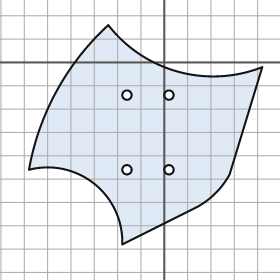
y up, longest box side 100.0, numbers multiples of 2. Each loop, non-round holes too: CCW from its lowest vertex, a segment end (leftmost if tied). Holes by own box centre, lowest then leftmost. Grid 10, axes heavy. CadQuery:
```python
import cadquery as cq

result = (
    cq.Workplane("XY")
    .moveTo(-18.0, -78.0)
    .lineTo(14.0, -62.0)
    .threePointArc((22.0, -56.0), (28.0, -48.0))
    .lineTo(42.0, -2.0)
    .threePointArc((6.0, -4.0), (-24.0, 16.0))
    .threePointArc((-46.0, -12.0), (-58.0, -46.0))
    .threePointArc((-30.0, -52.0), (-18.0, -78.0))
    .close()
    .moveTo(-16.0, -46.0)
    .circle(2.0)
    .moveTo(2.0, -46.0)
    .circle(2.0)
    .moveTo(-16.0, -14.0)
    .circle(2.0)
    .moveTo(2.0, -14.0)
    .circle(2.0)
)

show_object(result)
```